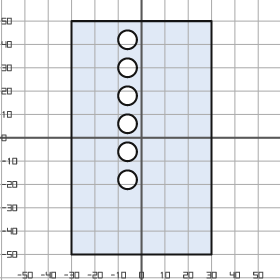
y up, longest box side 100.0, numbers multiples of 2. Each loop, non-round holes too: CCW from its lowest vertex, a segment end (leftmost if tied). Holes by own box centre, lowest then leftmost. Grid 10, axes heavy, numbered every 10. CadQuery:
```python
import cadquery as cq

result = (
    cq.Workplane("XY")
    .moveTo(-30.0, -50.0)
    .lineTo(30.0, -50.0)
    .lineTo(30.0, 50.0)
    .lineTo(-30.0, 50.0)
    .close()
    .moveTo(-6.0, -18.0)
    .circle(4.0)
    .moveTo(-6.0, -6.0)
    .circle(4.0)
    .moveTo(-6.0, 6.0)
    .circle(4.0)
    .moveTo(-6.0, 18.0)
    .circle(4.0)
    .moveTo(-6.0, 30.0)
    .circle(4.0)
    .moveTo(-6.0, 42.0)
    .circle(4.0)
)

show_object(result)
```